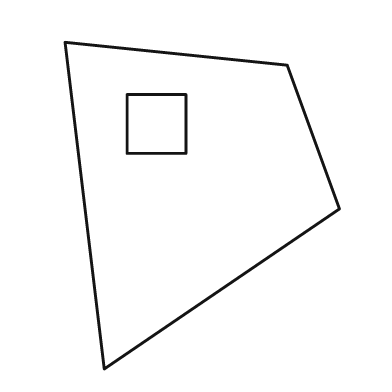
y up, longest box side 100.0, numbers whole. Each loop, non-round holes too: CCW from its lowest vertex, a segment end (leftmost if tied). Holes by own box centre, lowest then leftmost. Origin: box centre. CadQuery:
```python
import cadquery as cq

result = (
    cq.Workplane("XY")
    .moveTo(-30.0, -50.0)
    .lineTo(42.0, -1.0)
    .lineTo(26.0, 43.0)
    .lineTo(-42.0, 50.0)
    .close()
    .moveTo(-23.0, 16.0)
    .lineTo(-5.0, 16.0)
    .lineTo(-5.0, 34.0)
    .lineTo(-23.0, 34.0)
    .close()
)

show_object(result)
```